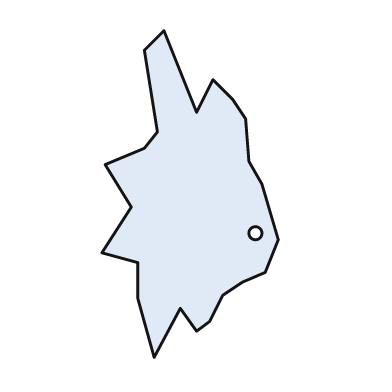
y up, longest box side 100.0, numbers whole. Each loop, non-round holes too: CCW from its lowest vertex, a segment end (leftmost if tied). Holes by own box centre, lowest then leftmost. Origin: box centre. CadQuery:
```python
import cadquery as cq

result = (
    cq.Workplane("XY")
    .moveTo(-11.0, -50.0)
    .lineTo(-3.0, -35.0)
    .lineTo(2.0, -42.0)
    .lineTo(6.0, -39.0)
    .lineTo(10.0, -31.0)
    .lineTo(16.0, -27.0)
    .lineTo(23.0, -24.0)
    .lineTo(27.0, -14.0)
    .lineTo(22.0, 3.0)
    .lineTo(18.0, 10.0)
    .lineTo(17.0, 23.0)
    .lineTo(13.0, 29.0)
    .lineTo(7.0, 35.0)
    .lineTo(2.0, 25.0)
    .lineTo(-8.0, 50.0)
    .lineTo(-14.0, 44.0)
    .lineTo(-10.0, 19.0)
    .lineTo(-14.0, 14.0)
    .lineTo(-26.0, 9.0)
    .lineTo(-18.0, -4.0)
    .lineTo(-27.0, -18.0)
    .lineTo(-16.0, -21.0)
    .lineTo(-16.0, -32.0)
    .close()
    .moveTo(20.0, -12.0)
    .circle(2.0)
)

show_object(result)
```